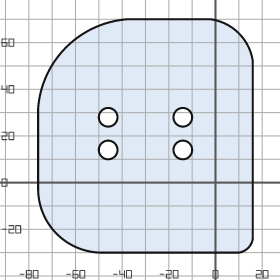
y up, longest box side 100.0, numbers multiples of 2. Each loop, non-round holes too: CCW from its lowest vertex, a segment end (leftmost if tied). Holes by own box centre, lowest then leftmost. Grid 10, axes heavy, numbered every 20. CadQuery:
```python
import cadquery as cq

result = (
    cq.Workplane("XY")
    .moveTo(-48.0, -30.0)
    .lineTo(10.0, -30.0)
    .threePointArc((14.0, -28.0), (16.0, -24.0))
    .lineTo(16.0, 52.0)
    .threePointArc((10.0, 64.0), (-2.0, 70.0))
    .lineTo(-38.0, 70.0)
    .threePointArc((-64.0, 58.0), (-76.0, 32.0))
    .lineTo(-76.0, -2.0)
    .threePointArc((-68.0, -22.0), (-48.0, -30.0))
    .close()
    .moveTo(-46.0, 14.0)
    .circle(4.0)
    .moveTo(-14.0, 14.0)
    .circle(4.0)
    .moveTo(-46.0, 28.0)
    .circle(4.0)
    .moveTo(-14.0, 28.0)
    .circle(4.0)
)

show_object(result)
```